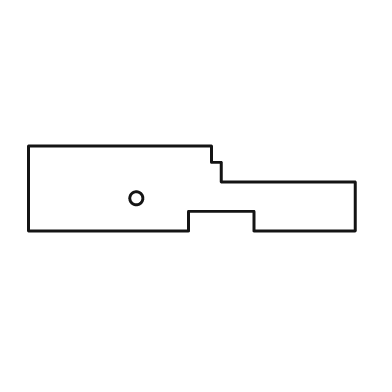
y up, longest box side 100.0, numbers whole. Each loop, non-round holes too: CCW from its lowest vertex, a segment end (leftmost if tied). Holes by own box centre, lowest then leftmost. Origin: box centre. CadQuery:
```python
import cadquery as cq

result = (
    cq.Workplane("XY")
    .moveTo(-50.0, -13.0)
    .lineTo(-1.0, -13.0)
    .lineTo(-1.0, -7.0)
    .lineTo(19.0, -7.0)
    .lineTo(19.0, -13.0)
    .lineTo(50.0, -13.0)
    .lineTo(50.0, 2.0)
    .lineTo(9.0, 2.0)
    .lineTo(9.0, 8.0)
    .lineTo(6.0, 8.0)
    .lineTo(6.0, 13.0)
    .lineTo(-50.0, 13.0)
    .close()
    .moveTo(-17.0, -3.0)
    .circle(2.0)
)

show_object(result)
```